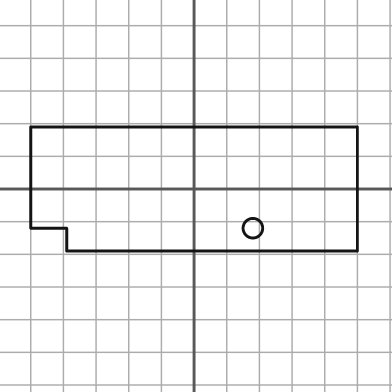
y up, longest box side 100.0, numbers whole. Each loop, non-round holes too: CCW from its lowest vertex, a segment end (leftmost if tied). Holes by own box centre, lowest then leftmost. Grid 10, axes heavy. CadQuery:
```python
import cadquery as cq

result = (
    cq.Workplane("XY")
    .moveTo(-39.0, -19.0)
    .lineTo(50.0, -19.0)
    .lineTo(50.0, 19.0)
    .lineTo(-50.0, 19.0)
    .lineTo(-50.0, -12.0)
    .lineTo(-39.0, -12.0)
    .close()
    .moveTo(18.0, -12.0)
    .circle(3.0)
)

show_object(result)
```